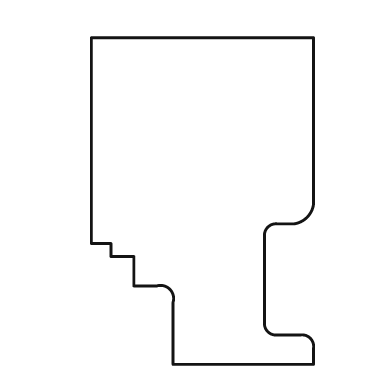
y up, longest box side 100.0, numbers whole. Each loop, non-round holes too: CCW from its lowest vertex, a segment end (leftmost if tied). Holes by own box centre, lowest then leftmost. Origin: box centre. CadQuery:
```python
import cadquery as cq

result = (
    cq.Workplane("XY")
    .moveTo(-9.0, -50.0)
    .lineTo(34.0, -50.0)
    .lineTo(34.0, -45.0)
    .threePointArc((33.0, -42.0), (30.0, -41.0))
    .lineTo(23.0, -41.0)
    .threePointArc((20.0, -40.0), (19.0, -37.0))
    .lineTo(19.0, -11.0)
    .threePointArc((20.0, -8.0), (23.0, -7.0))
    .lineTo(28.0, -7.0)
    .threePointArc((32.0, -5.0), (34.0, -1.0))
    .lineTo(34.0, 50.0)
    .lineTo(-34.0, 50.0)
    .lineTo(-34.0, -13.0)
    .lineTo(-28.0, -13.0)
    .lineTo(-28.0, -17.0)
    .lineTo(-21.0, -17.0)
    .lineTo(-21.0, -26.0)
    .lineTo(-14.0, -26.0)
    .threePointArc((-10.0, -27.0), (-9.0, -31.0))
    .close()
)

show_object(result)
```